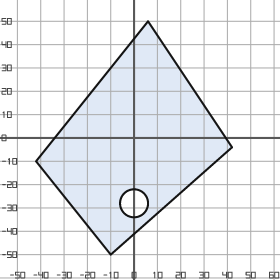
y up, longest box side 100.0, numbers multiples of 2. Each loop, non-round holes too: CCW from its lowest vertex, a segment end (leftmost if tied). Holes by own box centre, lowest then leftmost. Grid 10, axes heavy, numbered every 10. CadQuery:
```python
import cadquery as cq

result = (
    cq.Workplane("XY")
    .moveTo(-10.0, -50.0)
    .lineTo(42.0, -4.0)
    .lineTo(6.0, 50.0)
    .lineTo(-42.0, -10.0)
    .close()
    .moveTo(0.0, -28.0)
    .circle(6.0)
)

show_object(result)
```